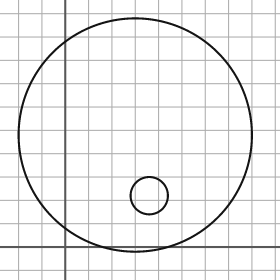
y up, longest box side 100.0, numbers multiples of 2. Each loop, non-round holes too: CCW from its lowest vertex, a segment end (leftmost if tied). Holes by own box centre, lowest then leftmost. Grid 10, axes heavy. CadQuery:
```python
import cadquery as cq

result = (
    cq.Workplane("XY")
    .moveTo(30.0, 48.0)
    .circle(50.0)
    .moveTo(36.0, 22.0)
    .circle(8.0)
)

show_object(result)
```